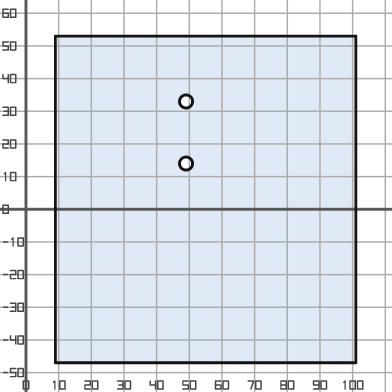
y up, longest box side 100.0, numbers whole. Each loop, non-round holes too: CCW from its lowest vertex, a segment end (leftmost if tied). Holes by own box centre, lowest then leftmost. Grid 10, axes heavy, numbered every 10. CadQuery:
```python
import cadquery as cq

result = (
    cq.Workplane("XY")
    .moveTo(9.0, -47.0)
    .lineTo(101.0, -47.0)
    .lineTo(101.0, 53.0)
    .lineTo(9.0, 53.0)
    .close()
    .moveTo(49.0, 14.0)
    .circle(2.0)
    .moveTo(49.0, 33.0)
    .circle(2.0)
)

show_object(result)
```